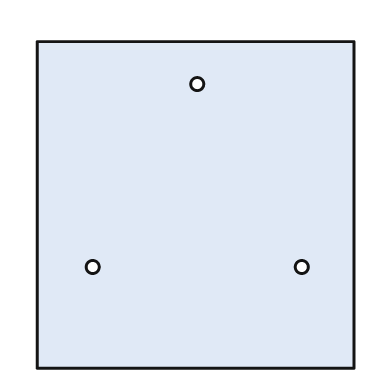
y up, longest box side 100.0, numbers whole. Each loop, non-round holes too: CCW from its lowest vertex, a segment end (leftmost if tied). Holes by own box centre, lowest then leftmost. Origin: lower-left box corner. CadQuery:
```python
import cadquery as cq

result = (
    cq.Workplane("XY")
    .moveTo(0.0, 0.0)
    .lineTo(97.0, 0.0)
    .lineTo(97.0, 100.0)
    .lineTo(0.0, 100.0)
    .close()
    .moveTo(17.0, 31.0)
    .circle(2.0)
    .moveTo(81.0, 31.0)
    .circle(2.0)
    .moveTo(49.0, 87.0)
    .circle(2.0)
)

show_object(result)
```